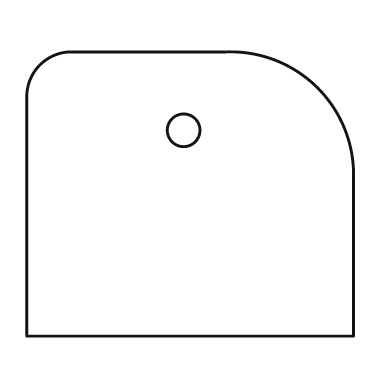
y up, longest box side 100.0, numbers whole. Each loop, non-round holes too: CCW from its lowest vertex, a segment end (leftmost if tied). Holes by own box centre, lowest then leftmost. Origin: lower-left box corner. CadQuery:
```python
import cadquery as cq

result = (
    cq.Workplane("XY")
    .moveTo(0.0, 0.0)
    .lineTo(100.0, 0.0)
    .lineTo(100.0, 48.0)
    .threePointArc((89.0, 76.0), (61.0, 87.0))
    .lineTo(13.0, 87.0)
    .threePointArc((4.0, 83.0), (0.0, 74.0))
    .close()
    .moveTo(48.0, 63.0)
    .circle(5.0)
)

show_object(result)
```